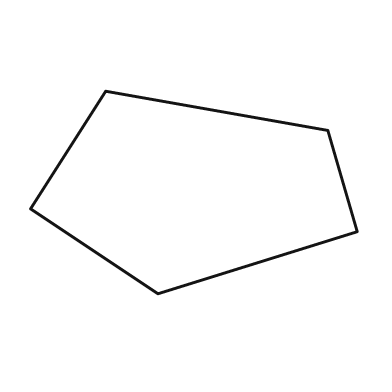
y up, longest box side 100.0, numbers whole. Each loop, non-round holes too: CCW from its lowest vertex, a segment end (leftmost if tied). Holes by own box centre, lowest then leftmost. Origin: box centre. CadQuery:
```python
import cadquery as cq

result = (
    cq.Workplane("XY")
    .moveTo(-11.0, -31.0)
    .lineTo(50.0, -12.0)
    .lineTo(41.0, 19.0)
    .lineTo(-27.0, 31.0)
    .lineTo(-50.0, -5.0)
    .close()
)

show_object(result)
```